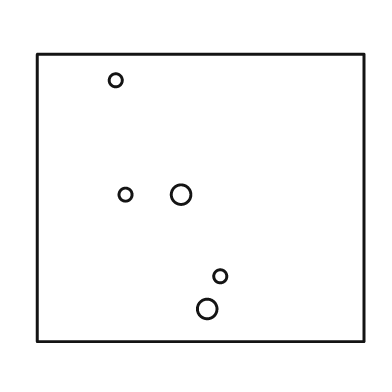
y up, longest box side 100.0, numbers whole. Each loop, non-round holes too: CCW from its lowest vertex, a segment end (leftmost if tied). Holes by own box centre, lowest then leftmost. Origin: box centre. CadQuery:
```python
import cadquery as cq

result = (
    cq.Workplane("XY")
    .moveTo(-50.0, -44.0)
    .lineTo(50.0, -44.0)
    .lineTo(50.0, 44.0)
    .lineTo(-50.0, 44.0)
    .close()
    .moveTo(2.0, -34.0)
    .circle(3.0)
    .moveTo(6.0, -24.0)
    .circle(2.0)
    .moveTo(-23.0, 1.0)
    .circle(2.0)
    .moveTo(-6.0, 1.0)
    .circle(3.0)
    .moveTo(-26.0, 36.0)
    .circle(2.0)
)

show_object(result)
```